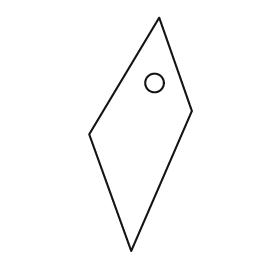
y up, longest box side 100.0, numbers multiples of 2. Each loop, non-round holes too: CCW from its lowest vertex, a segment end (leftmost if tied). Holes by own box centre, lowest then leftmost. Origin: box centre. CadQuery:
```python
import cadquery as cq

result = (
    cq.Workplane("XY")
    .moveTo(-4.0, -50.0)
    .lineTo(22.0, 10.0)
    .lineTo(8.0, 50.0)
    .lineTo(-22.0, 0.0)
    .close()
    .moveTo(6.0, 22.0)
    .circle(4.0)
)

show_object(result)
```